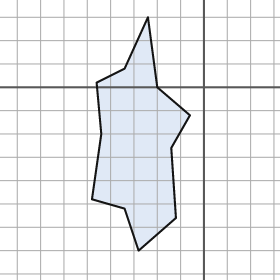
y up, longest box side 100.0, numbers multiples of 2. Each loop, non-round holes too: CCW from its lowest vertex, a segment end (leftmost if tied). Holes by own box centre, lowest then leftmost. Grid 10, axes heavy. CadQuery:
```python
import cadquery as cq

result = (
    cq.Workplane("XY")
    .moveTo(-28.0, -70.0)
    .lineTo(-12.0, -56.0)
    .lineTo(-14.0, -26.0)
    .lineTo(-6.0, -12.0)
    .lineTo(-20.0, 0.0)
    .lineTo(-24.0, 30.0)
    .lineTo(-34.0, 8.0)
    .lineTo(-46.0, 2.0)
    .lineTo(-44.0, -20.0)
    .lineTo(-48.0, -48.0)
    .lineTo(-34.0, -52.0)
    .close()
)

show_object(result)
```